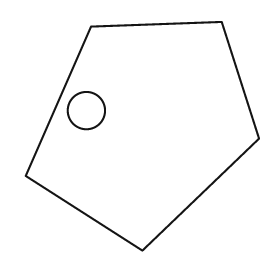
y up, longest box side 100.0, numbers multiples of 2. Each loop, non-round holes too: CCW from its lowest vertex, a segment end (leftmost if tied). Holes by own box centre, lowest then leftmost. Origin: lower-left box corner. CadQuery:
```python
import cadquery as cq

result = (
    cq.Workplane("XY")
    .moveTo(50.0, 0.0)
    .lineTo(100.0, 48.0)
    .lineTo(84.0, 98.0)
    .lineTo(28.0, 96.0)
    .lineTo(0.0, 32.0)
    .close()
    .moveTo(26.0, 60.0)
    .circle(8.0)
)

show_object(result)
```